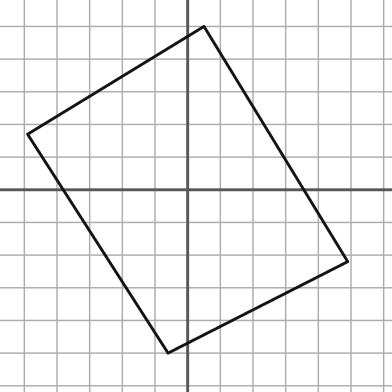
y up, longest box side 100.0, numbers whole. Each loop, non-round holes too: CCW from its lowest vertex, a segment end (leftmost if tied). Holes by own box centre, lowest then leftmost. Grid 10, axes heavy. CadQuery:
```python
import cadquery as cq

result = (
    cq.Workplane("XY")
    .moveTo(-6.0, -50.0)
    .lineTo(49.0, -22.0)
    .lineTo(5.0, 50.0)
    .lineTo(-49.0, 17.0)
    .close()
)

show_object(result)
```